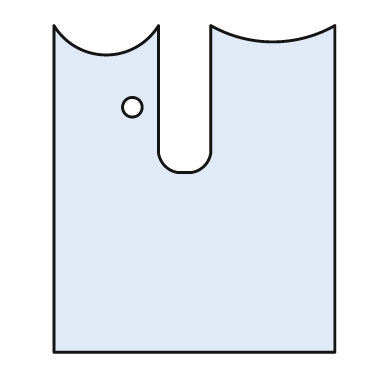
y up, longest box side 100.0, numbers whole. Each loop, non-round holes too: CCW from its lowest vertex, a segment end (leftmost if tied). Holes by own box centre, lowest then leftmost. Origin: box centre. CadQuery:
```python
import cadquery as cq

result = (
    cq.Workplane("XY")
    .moveTo(-43.0, -50.0)
    .lineTo(43.0, -50.0)
    .lineTo(43.0, 50.0)
    .threePointArc((24.0, 45.0), (5.0, 50.0))
    .lineTo(5.0, 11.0)
    .threePointArc((3.0, 7.0), (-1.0, 5.0))
    .lineTo(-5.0, 5.0)
    .threePointArc((-9.0, 7.0), (-11.0, 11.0))
    .lineTo(-11.0, 50.0)
    .threePointArc((-27.0, 41.0), (-43.0, 50.0))
    .close()
    .moveTo(-19.0, 25.0)
    .circle(3.0)
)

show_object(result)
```